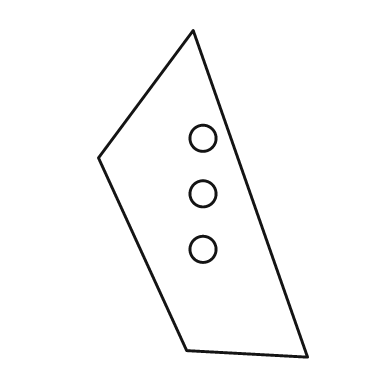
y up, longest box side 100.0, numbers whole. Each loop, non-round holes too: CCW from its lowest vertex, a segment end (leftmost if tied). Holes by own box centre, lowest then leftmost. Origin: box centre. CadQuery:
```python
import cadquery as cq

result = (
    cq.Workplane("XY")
    .moveTo(32.0, -50.0)
    .lineTo(-3.0, 50.0)
    .lineTo(-32.0, 11.0)
    .lineTo(-5.0, -48.0)
    .close()
    .moveTo(0.0, -17.0)
    .circle(4.0)
    .moveTo(0.0, 0.0)
    .circle(4.0)
    .moveTo(0.0, 17.0)
    .circle(4.0)
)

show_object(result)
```